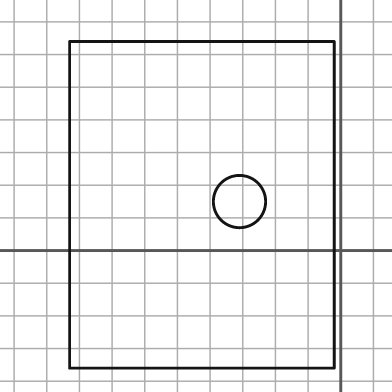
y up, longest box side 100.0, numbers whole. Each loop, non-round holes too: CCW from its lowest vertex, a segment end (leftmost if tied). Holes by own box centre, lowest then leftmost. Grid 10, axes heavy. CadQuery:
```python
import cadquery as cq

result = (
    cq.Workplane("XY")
    .moveTo(-83.0, -36.0)
    .lineTo(-2.0, -36.0)
    .lineTo(-2.0, 64.0)
    .lineTo(-83.0, 64.0)
    .close()
    .moveTo(-31.0, 15.0)
    .circle(8.0)
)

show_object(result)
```